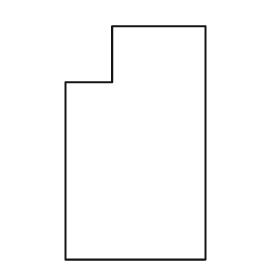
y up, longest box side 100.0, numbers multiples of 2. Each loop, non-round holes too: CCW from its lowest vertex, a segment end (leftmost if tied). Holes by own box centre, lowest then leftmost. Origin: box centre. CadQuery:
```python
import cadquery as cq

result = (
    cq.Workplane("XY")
    .moveTo(-30.0, -50.0)
    .lineTo(30.0, -50.0)
    .lineTo(30.0, 50.0)
    .lineTo(-10.0, 50.0)
    .lineTo(-10.0, 26.0)
    .lineTo(-30.0, 26.0)
    .close()
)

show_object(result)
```